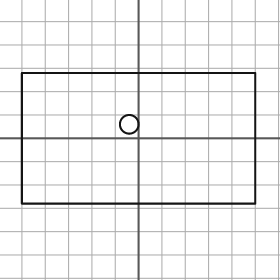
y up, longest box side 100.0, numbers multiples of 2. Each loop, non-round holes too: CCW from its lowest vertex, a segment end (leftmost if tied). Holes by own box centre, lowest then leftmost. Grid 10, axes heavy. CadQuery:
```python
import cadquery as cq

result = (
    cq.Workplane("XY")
    .moveTo(-50.0, -28.0)
    .lineTo(50.0, -28.0)
    .lineTo(50.0, 28.0)
    .lineTo(-50.0, 28.0)
    .close()
    .moveTo(-4.0, 6.0)
    .circle(4.0)
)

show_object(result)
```